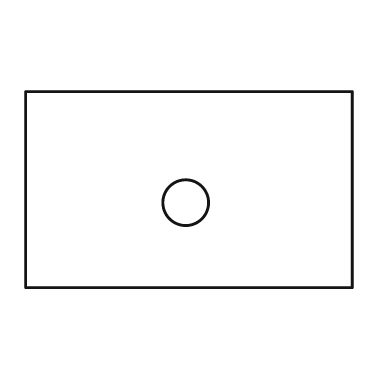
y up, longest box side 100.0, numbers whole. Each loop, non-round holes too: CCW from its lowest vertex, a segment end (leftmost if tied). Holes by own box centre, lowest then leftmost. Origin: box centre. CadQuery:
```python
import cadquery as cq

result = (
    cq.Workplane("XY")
    .moveTo(-50.0, -30.0)
    .lineTo(50.0, -30.0)
    .lineTo(50.0, 30.0)
    .lineTo(-50.0, 30.0)
    .close()
    .moveTo(-1.0, -4.0)
    .circle(7.0)
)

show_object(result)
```